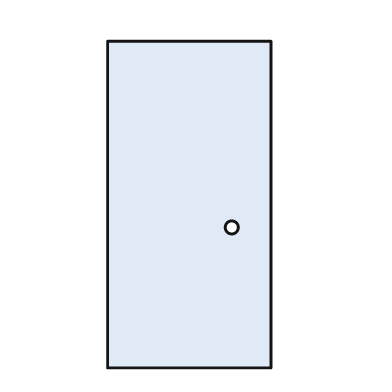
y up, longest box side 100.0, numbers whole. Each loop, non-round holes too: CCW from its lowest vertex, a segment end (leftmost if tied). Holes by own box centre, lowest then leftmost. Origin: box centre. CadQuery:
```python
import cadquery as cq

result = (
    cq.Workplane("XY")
    .moveTo(-25.0, -50.0)
    .lineTo(25.0, -50.0)
    .lineTo(25.0, 50.0)
    .lineTo(-25.0, 50.0)
    .close()
    .moveTo(13.0, -7.0)
    .circle(2.0)
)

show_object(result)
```